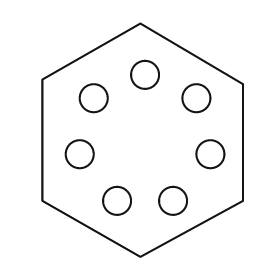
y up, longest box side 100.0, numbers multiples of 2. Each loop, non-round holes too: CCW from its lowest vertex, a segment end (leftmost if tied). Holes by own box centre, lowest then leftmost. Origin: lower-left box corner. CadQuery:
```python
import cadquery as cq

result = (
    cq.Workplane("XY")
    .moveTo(42.0, 0.0)
    .lineTo(86.0, 24.0)
    .lineTo(86.0, 74.0)
    .lineTo(42.0, 100.0)
    .lineTo(0.0, 76.0)
    .lineTo(0.0, 24.0)
    .close()
    .moveTo(32.0, 24.0)
    .circle(6.0)
    .moveTo(56.0, 24.0)
    .circle(6.0)
    .moveTo(16.0, 44.0)
    .circle(6.0)
    .moveTo(72.0, 44.0)
    .circle(6.0)
    .moveTo(22.0, 68.0)
    .circle(6.0)
    .moveTo(66.0, 68.0)
    .circle(6.0)
    .moveTo(44.0, 78.0)
    .circle(6.0)
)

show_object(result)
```